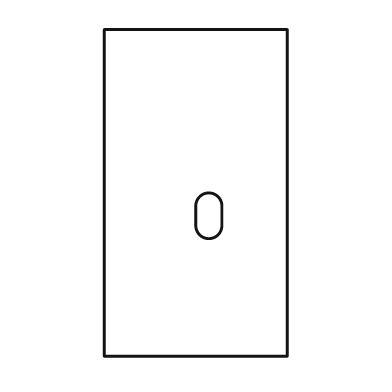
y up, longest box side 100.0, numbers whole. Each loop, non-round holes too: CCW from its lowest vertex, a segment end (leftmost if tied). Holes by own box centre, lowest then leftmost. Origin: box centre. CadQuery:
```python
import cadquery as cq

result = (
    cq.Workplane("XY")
    .moveTo(-28.0, -50.0)
    .lineTo(28.0, -50.0)
    .lineTo(28.0, 50.0)
    .lineTo(-28.0, 50.0)
    .close()
    .moveTo(0.0, -10.0)
    .threePointArc((4.0, -14.0), (8.0, -10.0))
    .lineTo(8.0, -4.0)
    .threePointArc((4.0, 0.0), (0.0, -4.0))
    .close()
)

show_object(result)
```